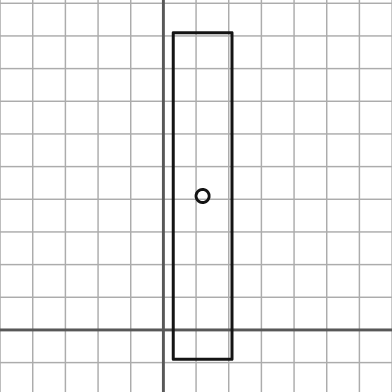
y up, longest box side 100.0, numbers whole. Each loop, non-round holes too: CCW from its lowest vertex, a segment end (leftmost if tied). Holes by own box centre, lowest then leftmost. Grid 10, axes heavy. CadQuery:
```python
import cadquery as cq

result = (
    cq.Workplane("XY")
    .moveTo(3.0, -9.0)
    .lineTo(21.0, -9.0)
    .lineTo(21.0, 91.0)
    .lineTo(3.0, 91.0)
    .close()
    .moveTo(12.0, 41.0)
    .circle(2.0)
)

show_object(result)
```